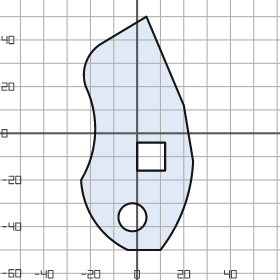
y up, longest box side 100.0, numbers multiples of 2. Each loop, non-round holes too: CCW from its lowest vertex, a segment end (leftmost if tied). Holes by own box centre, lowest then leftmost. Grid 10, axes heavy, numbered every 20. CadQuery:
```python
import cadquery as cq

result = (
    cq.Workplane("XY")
    .moveTo(-4.0, -50.0)
    .lineTo(10.0, -50.0)
    .threePointArc((20.0, -32.0), (24.0, -12.0))
    .lineTo(20.0, 12.0)
    .lineTo(4.0, 50.0)
    .lineTo(-16.0, 38.0)
    .threePointArc((-22.0, 30.0), (-22.0, 20.0))
    .threePointArc((-18.0, 0.0), (-24.0, -20.0))
    .threePointArc((-18.0, -38.0), (-4.0, -50.0))
    .close()
    .moveTo(-2.0, -36.0)
    .circle(6.0)
    .moveTo(0.0, -16.0)
    .lineTo(12.0, -16.0)
    .lineTo(12.0, -4.0)
    .lineTo(0.0, -4.0)
    .close()
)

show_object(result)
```